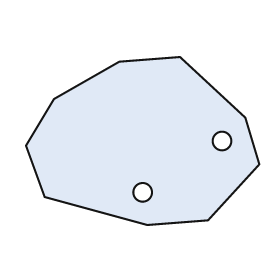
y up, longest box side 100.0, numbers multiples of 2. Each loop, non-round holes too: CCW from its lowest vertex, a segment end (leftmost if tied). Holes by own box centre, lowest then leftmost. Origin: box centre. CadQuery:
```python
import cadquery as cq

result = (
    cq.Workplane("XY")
    .moveTo(2.0, -36.0)
    .lineTo(28.0, -34.0)
    .lineTo(50.0, -10.0)
    .lineTo(44.0, 10.0)
    .lineTo(16.0, 36.0)
    .lineTo(-10.0, 34.0)
    .lineTo(-38.0, 18.0)
    .lineTo(-50.0, -2.0)
    .lineTo(-42.0, -24.0)
    .close()
    .moveTo(0.0, -22.0)
    .circle(4.0)
    .moveTo(34.0, 0.0)
    .circle(4.0)
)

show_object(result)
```